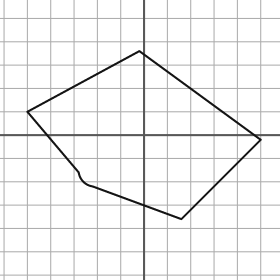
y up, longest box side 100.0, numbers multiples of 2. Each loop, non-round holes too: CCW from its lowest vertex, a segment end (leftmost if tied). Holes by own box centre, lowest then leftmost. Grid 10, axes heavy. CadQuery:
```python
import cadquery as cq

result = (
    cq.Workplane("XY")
    .moveTo(16.0, -36.0)
    .lineTo(50.0, -2.0)
    .lineTo(-2.0, 36.0)
    .lineTo(-50.0, 10.0)
    .lineTo(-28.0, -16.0)
    .threePointArc((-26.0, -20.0), (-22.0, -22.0))
    .close()
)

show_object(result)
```